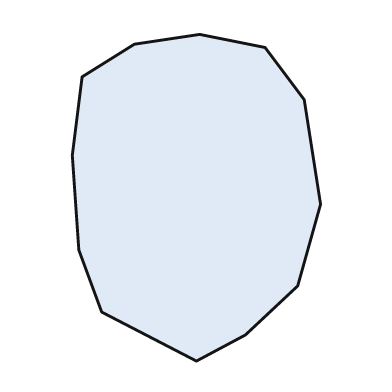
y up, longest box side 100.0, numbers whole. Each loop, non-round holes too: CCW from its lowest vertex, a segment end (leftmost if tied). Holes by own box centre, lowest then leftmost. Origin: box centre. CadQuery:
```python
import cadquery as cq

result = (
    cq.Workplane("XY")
    .moveTo(0.0, -50.0)
    .lineTo(15.0, -42.0)
    .lineTo(31.0, -27.0)
    .lineTo(38.0, -2.0)
    .lineTo(33.0, 30.0)
    .lineTo(21.0, 46.0)
    .lineTo(1.0, 50.0)
    .lineTo(-19.0, 47.0)
    .lineTo(-35.0, 37.0)
    .lineTo(-38.0, 13.0)
    .lineTo(-36.0, -16.0)
    .lineTo(-29.0, -35.0)
    .close()
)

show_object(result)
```